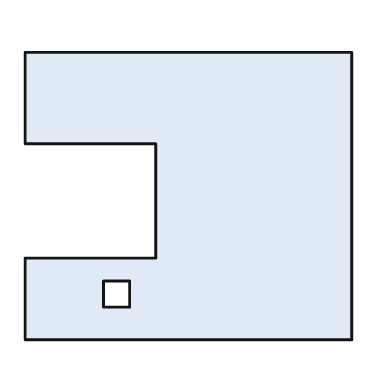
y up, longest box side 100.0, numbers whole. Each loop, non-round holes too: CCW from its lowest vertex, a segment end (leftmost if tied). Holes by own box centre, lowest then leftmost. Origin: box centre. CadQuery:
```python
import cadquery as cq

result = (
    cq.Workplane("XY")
    .moveTo(-50.0, -44.0)
    .lineTo(50.0, -44.0)
    .lineTo(50.0, 44.0)
    .lineTo(-50.0, 44.0)
    .lineTo(-50.0, 16.0)
    .lineTo(-10.0, 16.0)
    .lineTo(-10.0, -19.0)
    .lineTo(-50.0, -19.0)
    .close()
    .moveTo(-26.0, -34.0)
    .lineTo(-18.0, -34.0)
    .lineTo(-18.0, -26.0)
    .lineTo(-26.0, -26.0)
    .close()
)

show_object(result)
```